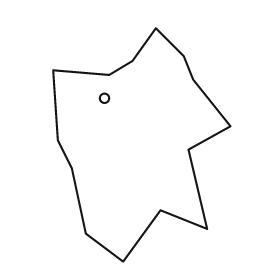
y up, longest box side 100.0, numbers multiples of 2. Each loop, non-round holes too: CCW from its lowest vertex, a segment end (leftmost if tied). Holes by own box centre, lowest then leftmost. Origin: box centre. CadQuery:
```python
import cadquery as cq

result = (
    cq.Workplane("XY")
    .moveTo(-8.0, -50.0)
    .lineTo(8.0, -28.0)
    .lineTo(28.0, -36.0)
    .lineTo(20.0, -2.0)
    .lineTo(38.0, 8.0)
    .lineTo(22.0, 28.0)
    .lineTo(18.0, 38.0)
    .lineTo(6.0, 50.0)
    .lineTo(-4.0, 36.0)
    .lineTo(-14.0, 30.0)
    .lineTo(-38.0, 32.0)
    .lineTo(-36.0, 2.0)
    .lineTo(-30.0, -10.0)
    .lineTo(-24.0, -38.0)
    .close()
    .moveTo(-16.0, 20.0)
    .circle(2.0)
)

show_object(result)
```